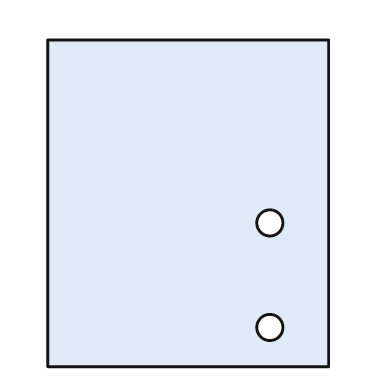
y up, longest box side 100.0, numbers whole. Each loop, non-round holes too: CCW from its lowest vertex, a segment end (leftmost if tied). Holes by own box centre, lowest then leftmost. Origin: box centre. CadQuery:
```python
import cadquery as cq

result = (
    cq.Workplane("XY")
    .moveTo(-43.0, -50.0)
    .lineTo(43.0, -50.0)
    .lineTo(43.0, 50.0)
    .lineTo(-43.0, 50.0)
    .close()
    .moveTo(25.0, -38.0)
    .circle(4.0)
    .moveTo(25.0, -6.0)
    .circle(4.0)
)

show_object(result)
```